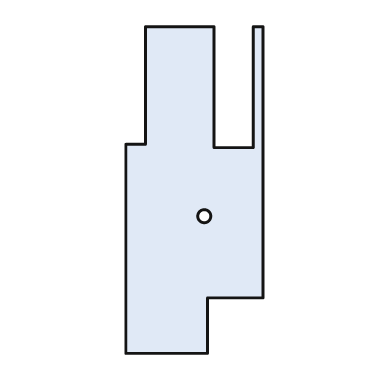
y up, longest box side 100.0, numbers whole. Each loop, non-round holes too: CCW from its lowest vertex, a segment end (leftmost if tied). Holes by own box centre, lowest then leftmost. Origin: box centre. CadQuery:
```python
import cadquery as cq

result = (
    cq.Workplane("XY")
    .moveTo(-21.0, -50.0)
    .lineTo(4.0, -50.0)
    .lineTo(4.0, -33.0)
    .lineTo(21.0, -33.0)
    .lineTo(21.0, 50.0)
    .lineTo(18.0, 50.0)
    .lineTo(18.0, 13.0)
    .lineTo(6.0, 13.0)
    .lineTo(6.0, 50.0)
    .lineTo(-15.0, 50.0)
    .lineTo(-15.0, 14.0)
    .lineTo(-21.0, 14.0)
    .close()
    .moveTo(3.0, -8.0)
    .circle(2.0)
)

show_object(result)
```